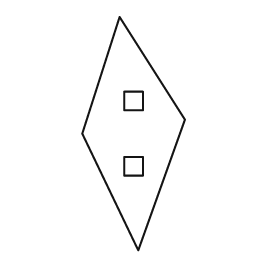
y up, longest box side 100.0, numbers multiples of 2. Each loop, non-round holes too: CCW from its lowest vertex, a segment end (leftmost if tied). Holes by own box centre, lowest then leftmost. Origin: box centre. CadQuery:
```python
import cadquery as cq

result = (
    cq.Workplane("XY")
    .moveTo(2.0, -50.0)
    .lineTo(22.0, 6.0)
    .lineTo(-6.0, 50.0)
    .lineTo(-22.0, 0.0)
    .close()
    .moveTo(-4.0, -18.0)
    .lineTo(4.0, -18.0)
    .lineTo(4.0, -10.0)
    .lineTo(-4.0, -10.0)
    .close()
    .moveTo(-4.0, 10.0)
    .lineTo(4.0, 10.0)
    .lineTo(4.0, 18.0)
    .lineTo(-4.0, 18.0)
    .close()
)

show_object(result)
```